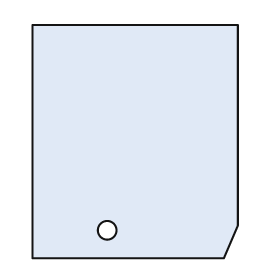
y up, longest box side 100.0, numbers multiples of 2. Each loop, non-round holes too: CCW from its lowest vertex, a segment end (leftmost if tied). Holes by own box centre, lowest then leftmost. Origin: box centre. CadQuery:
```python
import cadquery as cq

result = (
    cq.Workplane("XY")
    .moveTo(-44.0, -50.0)
    .lineTo(38.0, -50.0)
    .lineTo(44.0, -36.0)
    .lineTo(44.0, 50.0)
    .lineTo(-44.0, 50.0)
    .close()
    .moveTo(-12.0, -38.0)
    .circle(4.0)
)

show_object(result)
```